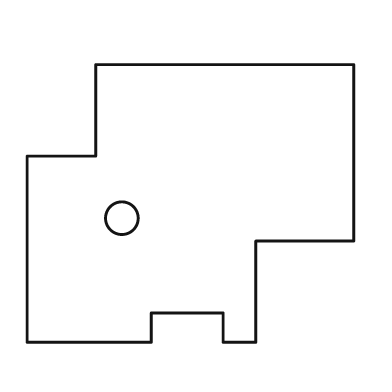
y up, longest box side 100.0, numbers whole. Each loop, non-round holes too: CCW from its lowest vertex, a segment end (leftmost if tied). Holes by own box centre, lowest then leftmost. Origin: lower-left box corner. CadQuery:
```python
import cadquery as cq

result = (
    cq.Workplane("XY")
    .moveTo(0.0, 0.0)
    .lineTo(38.0, 0.0)
    .lineTo(38.0, 9.0)
    .lineTo(60.0, 9.0)
    .lineTo(60.0, 0.0)
    .lineTo(70.0, 0.0)
    .lineTo(70.0, 31.0)
    .lineTo(100.0, 31.0)
    .lineTo(100.0, 85.0)
    .lineTo(21.0, 85.0)
    .lineTo(21.0, 57.0)
    .lineTo(0.0, 57.0)
    .close()
    .moveTo(29.0, 38.0)
    .circle(5.0)
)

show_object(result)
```